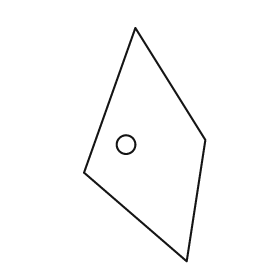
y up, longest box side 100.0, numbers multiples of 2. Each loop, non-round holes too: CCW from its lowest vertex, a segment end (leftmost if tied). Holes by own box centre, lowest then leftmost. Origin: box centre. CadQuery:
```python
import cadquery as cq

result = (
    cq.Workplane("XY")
    .moveTo(18.0, -50.0)
    .lineTo(26.0, 2.0)
    .lineTo(-4.0, 50.0)
    .lineTo(-26.0, -12.0)
    .close()
    .moveTo(-8.0, 0.0)
    .circle(4.0)
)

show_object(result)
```